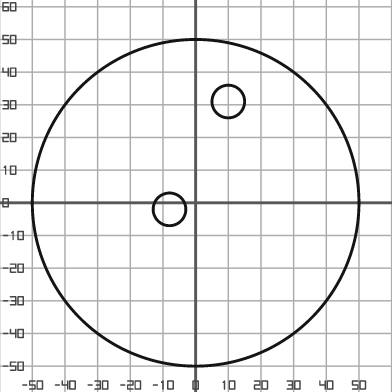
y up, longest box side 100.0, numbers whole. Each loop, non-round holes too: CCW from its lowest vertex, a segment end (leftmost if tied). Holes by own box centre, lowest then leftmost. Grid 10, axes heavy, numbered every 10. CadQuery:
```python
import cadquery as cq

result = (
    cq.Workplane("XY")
    .moveTo(0.0, 0.0)
    .circle(50.0)
    .moveTo(-8.0, -2.0)
    .circle(5.0)
    .moveTo(10.0, 31.0)
    .circle(5.0)
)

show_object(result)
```